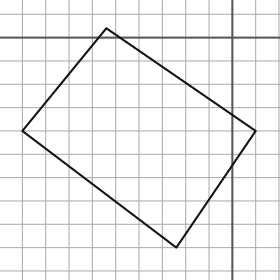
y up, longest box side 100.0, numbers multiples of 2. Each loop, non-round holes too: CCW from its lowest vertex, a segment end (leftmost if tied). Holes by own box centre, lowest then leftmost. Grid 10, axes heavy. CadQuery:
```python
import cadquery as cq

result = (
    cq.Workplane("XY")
    .moveTo(-24.0, -90.0)
    .lineTo(10.0, -40.0)
    .lineTo(-54.0, 4.0)
    .lineTo(-90.0, -40.0)
    .close()
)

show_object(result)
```